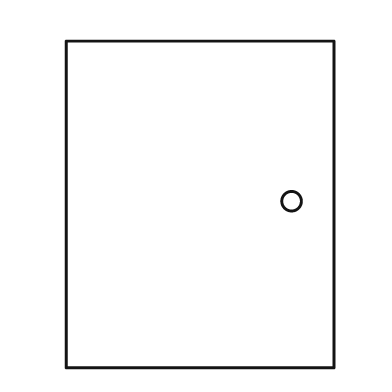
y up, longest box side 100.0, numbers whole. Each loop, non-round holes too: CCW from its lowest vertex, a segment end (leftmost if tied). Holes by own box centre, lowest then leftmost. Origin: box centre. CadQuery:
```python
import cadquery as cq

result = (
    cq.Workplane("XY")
    .moveTo(-41.0, -50.0)
    .lineTo(41.0, -50.0)
    .lineTo(41.0, 50.0)
    .lineTo(-41.0, 50.0)
    .close()
    .moveTo(28.0, 1.0)
    .circle(3.0)
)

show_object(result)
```